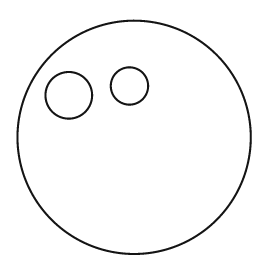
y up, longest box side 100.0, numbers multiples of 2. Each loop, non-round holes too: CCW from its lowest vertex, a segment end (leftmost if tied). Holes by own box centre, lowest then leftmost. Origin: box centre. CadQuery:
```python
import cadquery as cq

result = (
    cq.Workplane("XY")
    .moveTo(0.0, 0.0)
    .circle(50.0)
    .moveTo(-28.0, 18.0)
    .circle(10.0)
    .moveTo(-2.0, 22.0)
    .circle(8.0)
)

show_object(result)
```